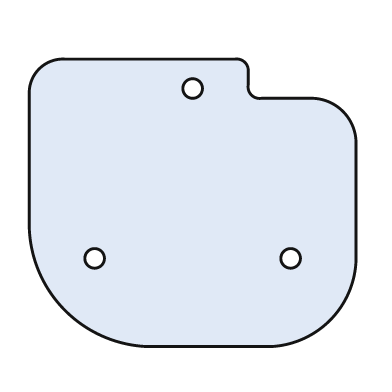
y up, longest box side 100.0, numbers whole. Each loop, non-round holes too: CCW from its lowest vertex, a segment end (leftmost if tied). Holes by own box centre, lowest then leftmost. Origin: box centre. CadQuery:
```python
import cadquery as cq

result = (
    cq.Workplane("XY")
    .moveTo(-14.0, -44.0)
    .lineTo(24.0, -44.0)
    .threePointArc((42.0, -36.0), (50.0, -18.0))
    .lineTo(50.0, 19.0)
    .threePointArc((46.0, 28.0), (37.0, 32.0))
    .lineTo(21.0, 32.0)
    .threePointArc((18.0, 33.0), (17.0, 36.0))
    .lineTo(17.0, 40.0)
    .threePointArc((16.0, 43.0), (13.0, 44.0))
    .lineTo(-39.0, 44.0)
    .threePointArc((-47.0, 41.0), (-50.0, 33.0))
    .lineTo(-50.0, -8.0)
    .threePointArc((-39.0, -33.0), (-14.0, -44.0))
    .close()
    .moveTo(-30.0, -17.0)
    .circle(3.0)
    .moveTo(30.0, -17.0)
    .circle(3.0)
    .moveTo(0.0, 35.0)
    .circle(3.0)
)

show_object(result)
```